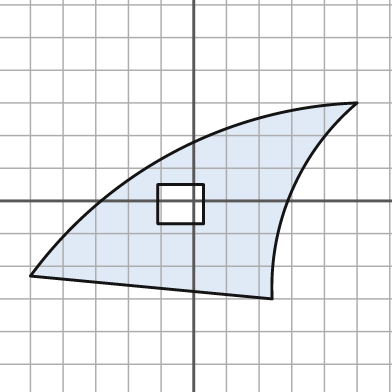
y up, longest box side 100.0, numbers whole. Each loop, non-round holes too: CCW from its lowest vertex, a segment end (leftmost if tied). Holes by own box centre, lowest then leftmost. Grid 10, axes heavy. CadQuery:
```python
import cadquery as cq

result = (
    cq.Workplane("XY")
    .moveTo(24.0, -30.0)
    .threePointArc((30.0, 3.0), (50.0, 30.0))
    .threePointArc((-6.0, 15.0), (-50.0, -23.0))
    .close()
    .moveTo(-11.0, -7.0)
    .lineTo(3.0, -7.0)
    .lineTo(3.0, 5.0)
    .lineTo(-11.0, 5.0)
    .close()
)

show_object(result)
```